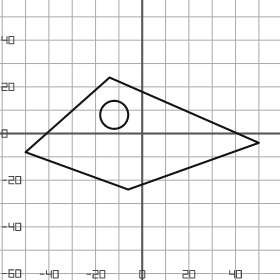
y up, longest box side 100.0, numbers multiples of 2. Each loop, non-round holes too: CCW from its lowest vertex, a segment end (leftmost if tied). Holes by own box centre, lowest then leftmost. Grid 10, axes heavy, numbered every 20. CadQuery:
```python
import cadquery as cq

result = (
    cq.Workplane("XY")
    .moveTo(-6.0, -24.0)
    .lineTo(50.0, -4.0)
    .lineTo(-14.0, 24.0)
    .lineTo(-50.0, -8.0)
    .close()
    .moveTo(-12.0, 8.0)
    .circle(6.0)
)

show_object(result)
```